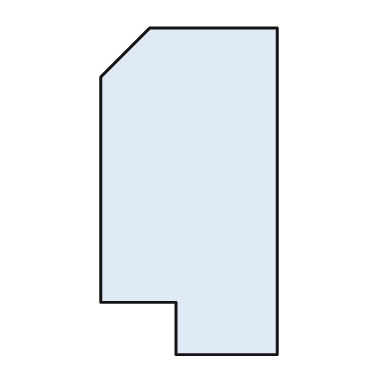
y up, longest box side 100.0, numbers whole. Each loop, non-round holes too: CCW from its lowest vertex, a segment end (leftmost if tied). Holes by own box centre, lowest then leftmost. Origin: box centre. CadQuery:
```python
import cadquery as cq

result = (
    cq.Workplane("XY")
    .moveTo(-4.0, -50.0)
    .lineTo(27.0, -50.0)
    .lineTo(27.0, 50.0)
    .lineTo(-12.0, 50.0)
    .lineTo(-27.0, 35.0)
    .lineTo(-27.0, -34.0)
    .lineTo(-4.0, -34.0)
    .close()
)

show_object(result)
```